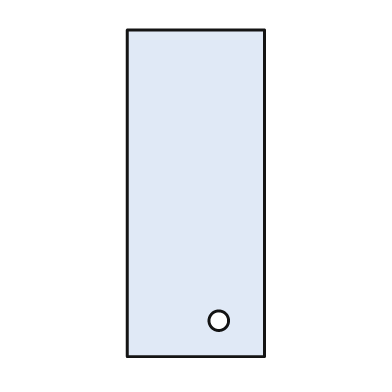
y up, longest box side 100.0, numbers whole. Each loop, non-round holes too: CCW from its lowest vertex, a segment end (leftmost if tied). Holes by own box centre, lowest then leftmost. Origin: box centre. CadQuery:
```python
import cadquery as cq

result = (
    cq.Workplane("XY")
    .moveTo(-21.0, -50.0)
    .lineTo(21.0, -50.0)
    .lineTo(21.0, 50.0)
    .lineTo(-21.0, 50.0)
    .close()
    .moveTo(7.0, -39.0)
    .circle(3.0)
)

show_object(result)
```